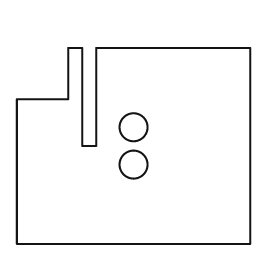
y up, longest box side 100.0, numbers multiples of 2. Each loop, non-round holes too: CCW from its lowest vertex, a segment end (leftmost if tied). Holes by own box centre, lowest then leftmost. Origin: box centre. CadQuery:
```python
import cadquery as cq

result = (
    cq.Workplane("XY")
    .moveTo(-50.0, -42.0)
    .lineTo(50.0, -42.0)
    .lineTo(50.0, 42.0)
    .lineTo(-16.0, 42.0)
    .lineTo(-16.0, 0.0)
    .lineTo(-22.0, 0.0)
    .lineTo(-22.0, 42.0)
    .lineTo(-28.0, 42.0)
    .lineTo(-28.0, 20.0)
    .lineTo(-50.0, 20.0)
    .close()
    .moveTo(0.0, -8.0)
    .circle(6.0)
    .moveTo(0.0, 8.0)
    .circle(6.0)
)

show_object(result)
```